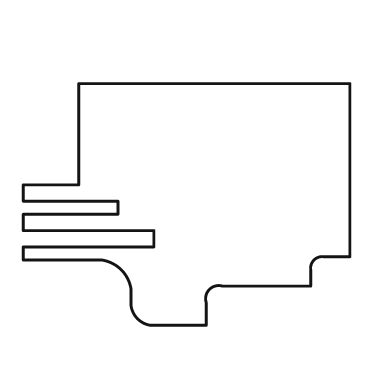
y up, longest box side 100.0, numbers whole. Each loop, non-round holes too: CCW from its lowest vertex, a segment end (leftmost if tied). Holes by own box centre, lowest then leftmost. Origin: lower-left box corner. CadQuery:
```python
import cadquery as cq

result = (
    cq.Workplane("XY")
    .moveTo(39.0, 0.0)
    .lineTo(56.0, 0.0)
    .lineTo(56.0, 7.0)
    .threePointArc((57.0, 11.0), (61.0, 12.0))
    .lineTo(88.0, 12.0)
    .lineTo(88.0, 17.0)
    .threePointArc((89.0, 20.0), (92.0, 21.0))
    .lineTo(100.0, 21.0)
    .lineTo(100.0, 74.0)
    .lineTo(17.0, 74.0)
    .lineTo(17.0, 43.0)
    .lineTo(0.0, 43.0)
    .lineTo(0.0, 38.0)
    .lineTo(29.0, 38.0)
    .lineTo(29.0, 34.0)
    .lineTo(0.0, 34.0)
    .lineTo(0.0, 29.0)
    .lineTo(40.0, 29.0)
    .lineTo(40.0, 24.0)
    .lineTo(0.0, 24.0)
    .lineTo(0.0, 20.0)
    .lineTo(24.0, 20.0)
    .threePointArc((30.0, 17.0), (33.0, 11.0))
    .lineTo(33.0, 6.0)
    .threePointArc((35.0, 2.0), (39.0, 0.0))
    .close()
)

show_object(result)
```